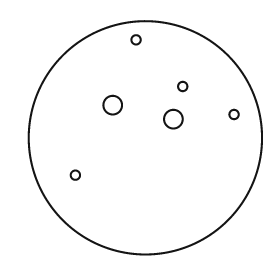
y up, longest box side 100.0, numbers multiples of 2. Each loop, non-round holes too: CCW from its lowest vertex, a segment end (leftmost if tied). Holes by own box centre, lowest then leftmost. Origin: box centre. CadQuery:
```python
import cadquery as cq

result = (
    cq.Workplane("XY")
    .moveTo(0.0, 0.0)
    .circle(50.0)
    .moveTo(-30.0, -16.0)
    .circle(2.0)
    .moveTo(12.0, 8.0)
    .circle(4.0)
    .moveTo(38.0, 10.0)
    .circle(2.0)
    .moveTo(-14.0, 14.0)
    .circle(4.0)
    .moveTo(16.0, 22.0)
    .circle(2.0)
    .moveTo(-4.0, 42.0)
    .circle(2.0)
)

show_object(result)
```